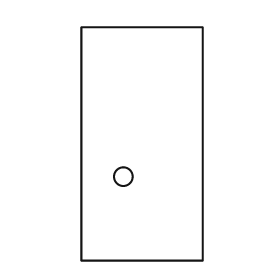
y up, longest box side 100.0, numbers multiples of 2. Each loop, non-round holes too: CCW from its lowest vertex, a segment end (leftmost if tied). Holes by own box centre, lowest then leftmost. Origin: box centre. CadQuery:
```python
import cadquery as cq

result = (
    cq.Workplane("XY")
    .moveTo(-26.0, -50.0)
    .lineTo(26.0, -50.0)
    .lineTo(26.0, 50.0)
    .lineTo(-26.0, 50.0)
    .close()
    .moveTo(-8.0, -14.0)
    .circle(4.0)
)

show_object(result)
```